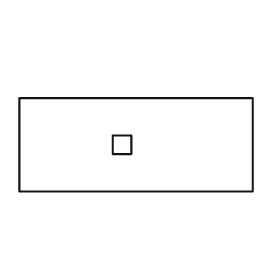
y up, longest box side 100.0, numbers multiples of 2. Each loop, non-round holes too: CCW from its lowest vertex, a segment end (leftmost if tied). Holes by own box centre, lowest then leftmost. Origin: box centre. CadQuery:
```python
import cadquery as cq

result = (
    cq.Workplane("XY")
    .moveTo(-50.0, -20.0)
    .lineTo(50.0, -20.0)
    .lineTo(50.0, 20.0)
    .lineTo(-50.0, 20.0)
    .close()
    .moveTo(-10.0, -4.0)
    .lineTo(-2.0, -4.0)
    .lineTo(-2.0, 4.0)
    .lineTo(-10.0, 4.0)
    .close()
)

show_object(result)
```